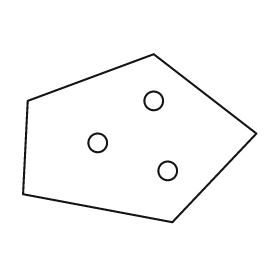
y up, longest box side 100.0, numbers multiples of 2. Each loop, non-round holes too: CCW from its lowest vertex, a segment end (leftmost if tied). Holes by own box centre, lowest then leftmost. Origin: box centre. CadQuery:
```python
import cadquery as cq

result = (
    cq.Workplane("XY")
    .moveTo(14.0, -36.0)
    .lineTo(50.0, 2.0)
    .lineTo(6.0, 36.0)
    .lineTo(-48.0, 16.0)
    .lineTo(-50.0, -24.0)
    .close()
    .moveTo(12.0, -14.0)
    .circle(4.0)
    .moveTo(-18.0, -2.0)
    .circle(4.0)
    .moveTo(6.0, 16.0)
    .circle(4.0)
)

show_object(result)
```